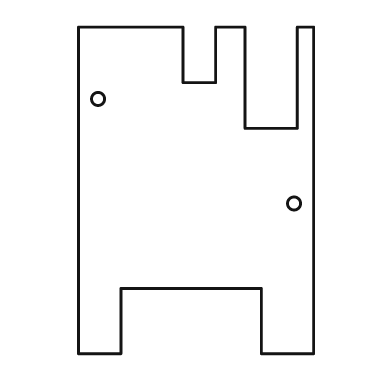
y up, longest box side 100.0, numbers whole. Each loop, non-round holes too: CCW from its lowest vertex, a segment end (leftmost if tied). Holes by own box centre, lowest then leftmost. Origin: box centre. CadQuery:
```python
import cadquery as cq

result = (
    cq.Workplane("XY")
    .moveTo(-36.0, -50.0)
    .lineTo(-23.0, -50.0)
    .lineTo(-23.0, -30.0)
    .lineTo(20.0, -30.0)
    .lineTo(20.0, -50.0)
    .lineTo(36.0, -50.0)
    .lineTo(36.0, 50.0)
    .lineTo(31.0, 50.0)
    .lineTo(31.0, 19.0)
    .lineTo(15.0, 19.0)
    .lineTo(15.0, 50.0)
    .lineTo(6.0, 50.0)
    .lineTo(6.0, 33.0)
    .lineTo(-4.0, 33.0)
    .lineTo(-4.0, 50.0)
    .lineTo(-36.0, 50.0)
    .close()
    .moveTo(30.0, -4.0)
    .circle(2.0)
    .moveTo(-30.0, 28.0)
    .circle(2.0)
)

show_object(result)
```